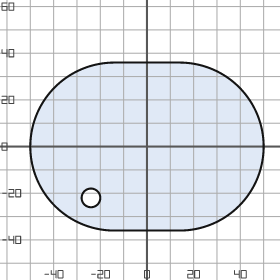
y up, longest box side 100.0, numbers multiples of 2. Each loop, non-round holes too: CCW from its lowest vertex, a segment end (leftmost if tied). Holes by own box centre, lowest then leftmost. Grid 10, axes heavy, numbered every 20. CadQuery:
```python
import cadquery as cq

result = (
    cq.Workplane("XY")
    .moveTo(-14.0, -36.0)
    .lineTo(14.0, -36.0)
    .threePointArc((50.0, 0.0), (14.0, 36.0))
    .lineTo(-14.0, 36.0)
    .threePointArc((-50.0, 0.0), (-14.0, -36.0))
    .close()
    .moveTo(-24.0, -22.0)
    .circle(4.0)
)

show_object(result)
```